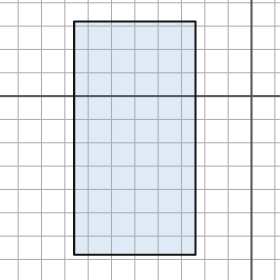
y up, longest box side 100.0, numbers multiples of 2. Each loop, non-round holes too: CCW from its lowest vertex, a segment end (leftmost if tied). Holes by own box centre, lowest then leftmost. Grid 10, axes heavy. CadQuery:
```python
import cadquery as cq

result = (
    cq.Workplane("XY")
    .moveTo(-76.0, -68.0)
    .lineTo(-24.0, -68.0)
    .lineTo(-24.0, 32.0)
    .lineTo(-76.0, 32.0)
    .close()
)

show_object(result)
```